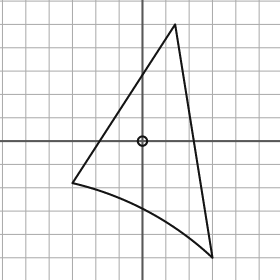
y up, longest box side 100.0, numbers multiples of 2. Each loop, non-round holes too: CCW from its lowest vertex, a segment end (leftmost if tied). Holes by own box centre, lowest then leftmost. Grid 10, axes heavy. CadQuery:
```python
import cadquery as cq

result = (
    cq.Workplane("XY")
    .moveTo(30.0, -50.0)
    .lineTo(14.0, 50.0)
    .lineTo(-30.0, -18.0)
    .threePointArc((2.0, -30.0), (30.0, -50.0))
    .close()
    .moveTo(0.0, 0.0)
    .circle(2.0)
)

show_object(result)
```